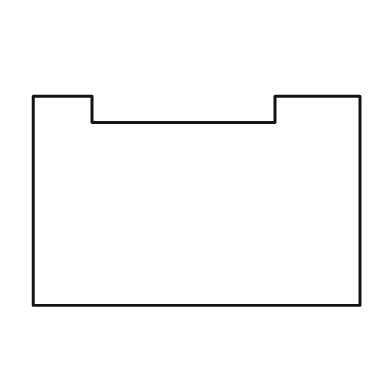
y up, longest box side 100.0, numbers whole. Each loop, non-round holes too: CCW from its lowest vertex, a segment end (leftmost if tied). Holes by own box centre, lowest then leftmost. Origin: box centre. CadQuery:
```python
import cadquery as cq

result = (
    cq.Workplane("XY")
    .moveTo(-50.0, -32.0)
    .lineTo(50.0, -32.0)
    .lineTo(50.0, 32.0)
    .lineTo(24.0, 32.0)
    .lineTo(24.0, 24.0)
    .lineTo(-32.0, 24.0)
    .lineTo(-32.0, 32.0)
    .lineTo(-50.0, 32.0)
    .close()
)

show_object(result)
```